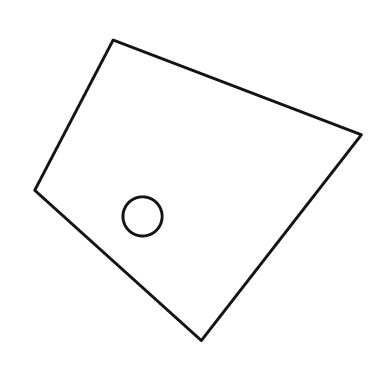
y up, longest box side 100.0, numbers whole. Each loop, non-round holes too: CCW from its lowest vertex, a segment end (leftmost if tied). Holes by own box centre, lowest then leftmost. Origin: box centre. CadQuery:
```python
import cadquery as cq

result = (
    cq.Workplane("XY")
    .moveTo(1.0, -46.0)
    .lineTo(50.0, 17.0)
    .lineTo(-26.0, 46.0)
    .lineTo(-50.0, 0.0)
    .close()
    .moveTo(-17.0, -8.0)
    .circle(6.0)
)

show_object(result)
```